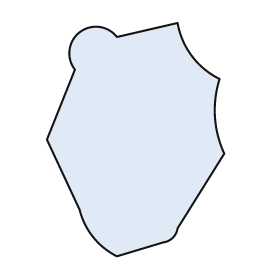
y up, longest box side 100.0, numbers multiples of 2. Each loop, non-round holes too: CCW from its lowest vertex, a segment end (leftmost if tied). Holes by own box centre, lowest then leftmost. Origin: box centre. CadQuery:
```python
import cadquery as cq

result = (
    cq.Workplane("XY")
    .moveTo(-8.0, -50.0)
    .lineTo(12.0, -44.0)
    .threePointArc((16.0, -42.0), (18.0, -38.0))
    .lineTo(38.0, -6.0)
    .threePointArc((34.0, 10.0), (36.0, 26.0))
    .threePointArc((24.0, 36.0), (18.0, 50.0))
    .lineTo(-8.0, 44.0)
    .threePointArc((-24.0, 46.0), (-26.0, 30.0))
    .lineTo(-38.0, 0.0)
    .lineTo(-24.0, -30.0)
    .threePointArc((-18.0, -42.0), (-8.0, -50.0))
    .close()
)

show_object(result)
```